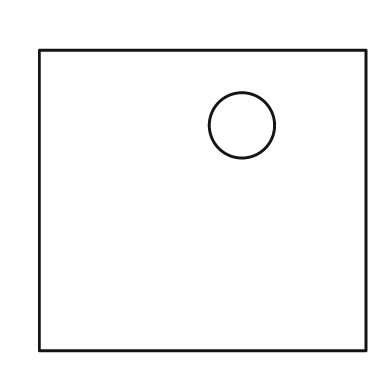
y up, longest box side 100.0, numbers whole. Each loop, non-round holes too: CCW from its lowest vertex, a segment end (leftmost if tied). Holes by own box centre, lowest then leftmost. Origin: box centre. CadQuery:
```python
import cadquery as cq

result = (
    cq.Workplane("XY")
    .moveTo(-50.0, -46.0)
    .lineTo(50.0, -46.0)
    .lineTo(50.0, 46.0)
    .lineTo(-50.0, 46.0)
    .close()
    .moveTo(12.0, 23.0)
    .circle(10.0)
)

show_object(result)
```